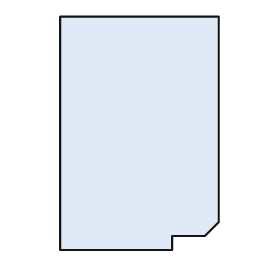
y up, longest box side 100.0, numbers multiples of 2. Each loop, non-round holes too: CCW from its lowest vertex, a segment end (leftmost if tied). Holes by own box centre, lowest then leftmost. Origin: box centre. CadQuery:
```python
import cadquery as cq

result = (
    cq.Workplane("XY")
    .moveTo(-34.0, -50.0)
    .lineTo(14.0, -50.0)
    .lineTo(14.0, -44.0)
    .lineTo(28.0, -44.0)
    .lineTo(34.0, -38.0)
    .lineTo(34.0, 50.0)
    .lineTo(-34.0, 50.0)
    .close()
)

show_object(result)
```